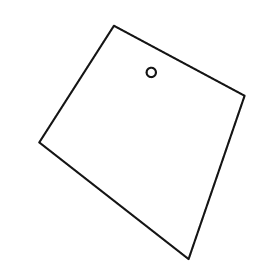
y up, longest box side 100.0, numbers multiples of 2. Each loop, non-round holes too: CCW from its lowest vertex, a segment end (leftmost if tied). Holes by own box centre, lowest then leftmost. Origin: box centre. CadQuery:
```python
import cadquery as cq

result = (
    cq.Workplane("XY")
    .moveTo(20.0, -50.0)
    .lineTo(44.0, 20.0)
    .lineTo(-12.0, 50.0)
    .lineTo(-44.0, 0.0)
    .close()
    .moveTo(4.0, 30.0)
    .circle(2.0)
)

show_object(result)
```